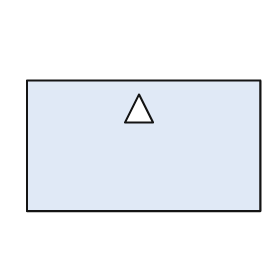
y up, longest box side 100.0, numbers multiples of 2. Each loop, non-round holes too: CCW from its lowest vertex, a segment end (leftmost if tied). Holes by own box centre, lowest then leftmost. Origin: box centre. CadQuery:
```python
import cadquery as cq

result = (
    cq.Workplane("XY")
    .moveTo(-50.0, -28.0)
    .lineTo(50.0, -28.0)
    .lineTo(50.0, 28.0)
    .lineTo(-50.0, 28.0)
    .close()
    .moveTo(-8.0, 10.0)
    .lineTo(4.0, 10.0)
    .lineTo(-2.0, 22.0)
    .close()
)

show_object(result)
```